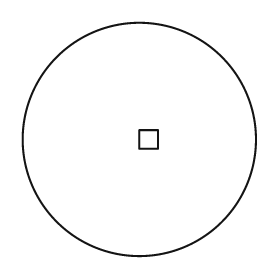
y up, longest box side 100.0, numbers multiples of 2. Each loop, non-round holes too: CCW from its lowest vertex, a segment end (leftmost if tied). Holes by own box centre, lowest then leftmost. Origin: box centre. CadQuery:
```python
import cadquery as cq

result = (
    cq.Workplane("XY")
    .moveTo(0.0, 0.0)
    .circle(50.0)
    .moveTo(0.0, -4.0)
    .lineTo(8.0, -4.0)
    .lineTo(8.0, 4.0)
    .lineTo(0.0, 4.0)
    .close()
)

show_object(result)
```